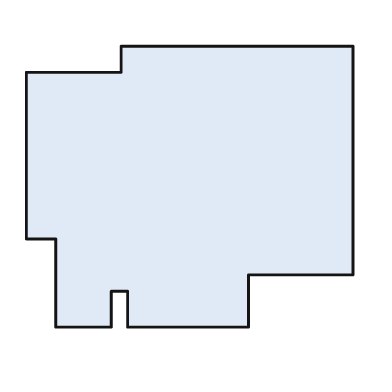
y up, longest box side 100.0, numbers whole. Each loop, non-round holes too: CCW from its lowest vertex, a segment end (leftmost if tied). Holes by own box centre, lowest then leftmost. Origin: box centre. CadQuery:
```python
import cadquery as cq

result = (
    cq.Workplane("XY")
    .moveTo(-41.0, -43.0)
    .lineTo(-24.0, -43.0)
    .lineTo(-24.0, -32.0)
    .lineTo(-19.0, -32.0)
    .lineTo(-19.0, -43.0)
    .lineTo(18.0, -43.0)
    .lineTo(18.0, -27.0)
    .lineTo(50.0, -27.0)
    .lineTo(50.0, 43.0)
    .lineTo(-21.0, 43.0)
    .lineTo(-21.0, 35.0)
    .lineTo(-50.0, 35.0)
    .lineTo(-50.0, -16.0)
    .lineTo(-41.0, -16.0)
    .close()
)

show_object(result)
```